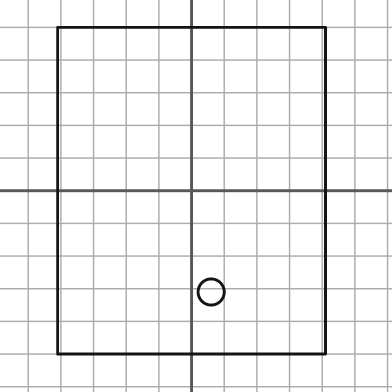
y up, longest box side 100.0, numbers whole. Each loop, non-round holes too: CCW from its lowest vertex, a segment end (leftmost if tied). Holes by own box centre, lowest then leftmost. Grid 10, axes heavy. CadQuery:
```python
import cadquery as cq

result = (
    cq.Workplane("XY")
    .moveTo(-41.0, -50.0)
    .lineTo(41.0, -50.0)
    .lineTo(41.0, 50.0)
    .lineTo(-41.0, 50.0)
    .close()
    .moveTo(6.0, -31.0)
    .circle(4.0)
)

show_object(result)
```